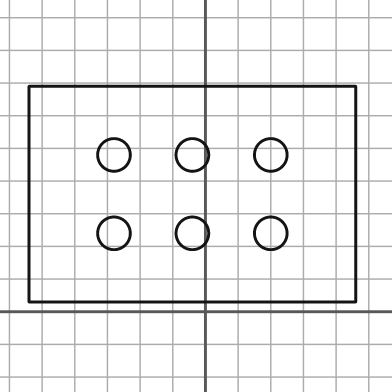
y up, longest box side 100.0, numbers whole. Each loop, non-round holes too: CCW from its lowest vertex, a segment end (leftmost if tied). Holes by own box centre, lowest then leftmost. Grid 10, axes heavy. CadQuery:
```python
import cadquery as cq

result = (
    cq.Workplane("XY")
    .moveTo(-54.0, 3.0)
    .lineTo(46.0, 3.0)
    .lineTo(46.0, 69.0)
    .lineTo(-54.0, 69.0)
    .close()
    .moveTo(-28.0, 24.0)
    .circle(5.0)
    .moveTo(-4.0, 24.0)
    .circle(5.0)
    .moveTo(20.0, 24.0)
    .circle(5.0)
    .moveTo(-28.0, 48.0)
    .circle(5.0)
    .moveTo(-4.0, 48.0)
    .circle(5.0)
    .moveTo(20.0, 48.0)
    .circle(5.0)
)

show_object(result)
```